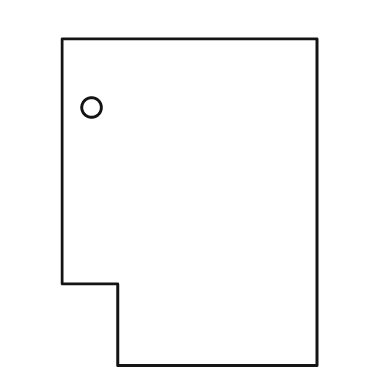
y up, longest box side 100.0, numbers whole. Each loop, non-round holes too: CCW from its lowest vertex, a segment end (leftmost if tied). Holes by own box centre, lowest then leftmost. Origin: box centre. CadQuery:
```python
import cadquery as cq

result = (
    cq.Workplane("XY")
    .moveTo(-22.0, -50.0)
    .lineTo(39.0, -50.0)
    .lineTo(39.0, 50.0)
    .lineTo(-39.0, 50.0)
    .lineTo(-39.0, -25.0)
    .lineTo(-22.0, -25.0)
    .close()
    .moveTo(-30.0, 29.0)
    .circle(3.0)
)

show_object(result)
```